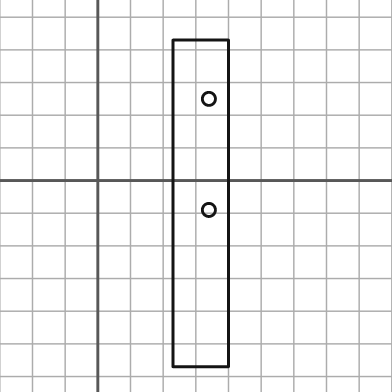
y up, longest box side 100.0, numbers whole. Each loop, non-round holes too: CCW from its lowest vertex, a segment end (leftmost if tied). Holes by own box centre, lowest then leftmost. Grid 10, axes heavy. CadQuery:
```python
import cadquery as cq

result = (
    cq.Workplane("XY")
    .moveTo(23.0, -57.0)
    .lineTo(40.0, -57.0)
    .lineTo(40.0, 43.0)
    .lineTo(23.0, 43.0)
    .close()
    .moveTo(34.0, -9.0)
    .circle(2.0)
    .moveTo(34.0, 25.0)
    .circle(2.0)
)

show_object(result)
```